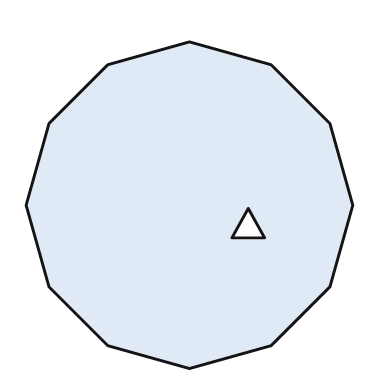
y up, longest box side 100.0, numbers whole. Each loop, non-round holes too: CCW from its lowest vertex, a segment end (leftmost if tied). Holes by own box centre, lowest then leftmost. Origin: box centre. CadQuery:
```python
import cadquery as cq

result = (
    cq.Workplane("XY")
    .moveTo(0.0, -50.0)
    .lineTo(25.0, -43.0)
    .lineTo(43.0, -25.0)
    .lineTo(50.0, 0.0)
    .lineTo(43.0, 25.0)
    .lineTo(25.0, 43.0)
    .lineTo(0.0, 50.0)
    .lineTo(-25.0, 43.0)
    .lineTo(-43.0, 25.0)
    .lineTo(-50.0, 0.0)
    .lineTo(-43.0, -25.0)
    .lineTo(-25.0, -43.0)
    .close()
    .moveTo(13.0, -10.0)
    .lineTo(23.0, -10.0)
    .lineTo(18.0, -1.0)
    .close()
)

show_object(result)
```